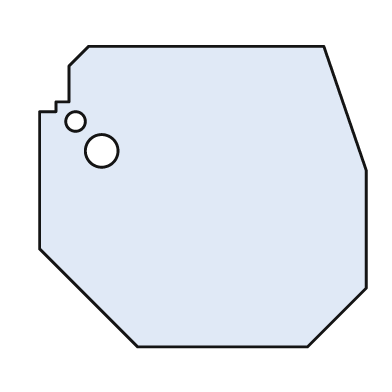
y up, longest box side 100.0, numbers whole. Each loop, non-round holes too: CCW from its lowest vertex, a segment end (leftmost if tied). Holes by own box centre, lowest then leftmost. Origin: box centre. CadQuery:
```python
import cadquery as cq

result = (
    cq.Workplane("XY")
    .moveTo(-20.0, -46.0)
    .lineTo(32.0, -46.0)
    .lineTo(50.0, -28.0)
    .lineTo(50.0, 8.0)
    .lineTo(37.0, 46.0)
    .lineTo(-35.0, 46.0)
    .lineTo(-41.0, 40.0)
    .lineTo(-41.0, 29.0)
    .lineTo(-45.0, 29.0)
    .lineTo(-45.0, 26.0)
    .lineTo(-50.0, 26.0)
    .lineTo(-50.0, -16.0)
    .close()
    .moveTo(-31.0, 14.0)
    .circle(5.0)
    .moveTo(-39.0, 23.0)
    .circle(3.0)
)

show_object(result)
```